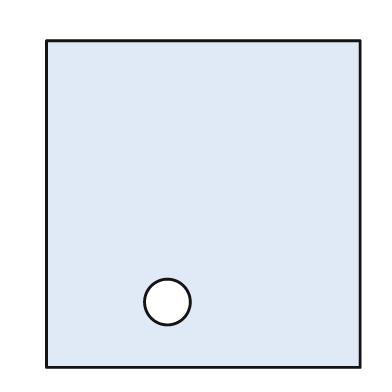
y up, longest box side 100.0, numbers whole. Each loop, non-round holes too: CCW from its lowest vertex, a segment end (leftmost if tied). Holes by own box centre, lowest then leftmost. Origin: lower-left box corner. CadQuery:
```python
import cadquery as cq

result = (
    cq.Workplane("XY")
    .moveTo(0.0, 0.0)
    .lineTo(96.0, 0.0)
    .lineTo(96.0, 100.0)
    .lineTo(0.0, 100.0)
    .close()
    .moveTo(37.0, 20.0)
    .circle(7.0)
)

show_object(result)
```